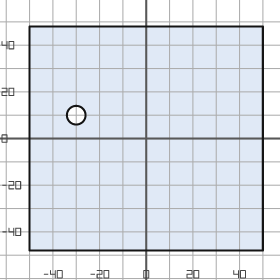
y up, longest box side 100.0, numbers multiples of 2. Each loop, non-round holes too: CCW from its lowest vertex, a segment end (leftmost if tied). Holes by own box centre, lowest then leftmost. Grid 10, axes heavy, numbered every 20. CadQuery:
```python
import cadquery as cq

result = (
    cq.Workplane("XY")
    .moveTo(-50.0, -48.0)
    .lineTo(50.0, -48.0)
    .lineTo(50.0, 48.0)
    .lineTo(-50.0, 48.0)
    .close()
    .moveTo(-30.0, 10.0)
    .circle(4.0)
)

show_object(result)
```